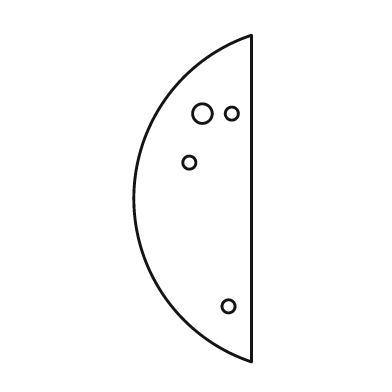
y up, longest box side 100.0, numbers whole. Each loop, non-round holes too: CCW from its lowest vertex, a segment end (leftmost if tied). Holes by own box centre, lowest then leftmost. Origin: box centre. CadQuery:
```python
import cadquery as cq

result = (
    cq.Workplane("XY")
    .moveTo(18.0, -50.0)
    .lineTo(18.0, 50.0)
    .threePointArc((-18.0, 0.0), (18.0, -50.0))
    .close()
    .moveTo(11.0, -33.0)
    .circle(2.0)
    .moveTo(-1.0, 11.0)
    .circle(2.0)
    .moveTo(3.0, 26.0)
    .circle(3.0)
    .moveTo(12.0, 26.0)
    .circle(2.0)
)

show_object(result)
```